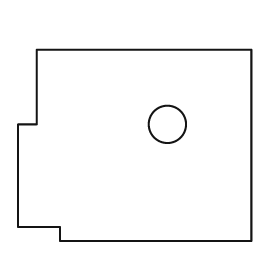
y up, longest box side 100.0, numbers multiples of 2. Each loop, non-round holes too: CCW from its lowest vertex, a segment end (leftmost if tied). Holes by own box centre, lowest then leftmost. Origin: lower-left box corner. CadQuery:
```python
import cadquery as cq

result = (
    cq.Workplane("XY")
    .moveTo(18.0, 0.0)
    .lineTo(100.0, 0.0)
    .lineTo(100.0, 82.0)
    .lineTo(8.0, 82.0)
    .lineTo(8.0, 50.0)
    .lineTo(0.0, 50.0)
    .lineTo(0.0, 6.0)
    .lineTo(18.0, 6.0)
    .close()
    .moveTo(64.0, 50.0)
    .circle(8.0)
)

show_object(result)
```